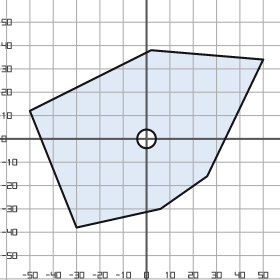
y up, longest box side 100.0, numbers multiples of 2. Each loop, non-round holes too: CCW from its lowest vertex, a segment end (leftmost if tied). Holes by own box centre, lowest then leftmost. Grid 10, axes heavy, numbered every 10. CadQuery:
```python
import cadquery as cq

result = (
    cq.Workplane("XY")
    .moveTo(-30.0, -38.0)
    .lineTo(6.0, -30.0)
    .lineTo(26.0, -16.0)
    .lineTo(50.0, 34.0)
    .lineTo(2.0, 38.0)
    .lineTo(-50.0, 12.0)
    .close()
    .moveTo(0.0, 0.0)
    .circle(4.0)
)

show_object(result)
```